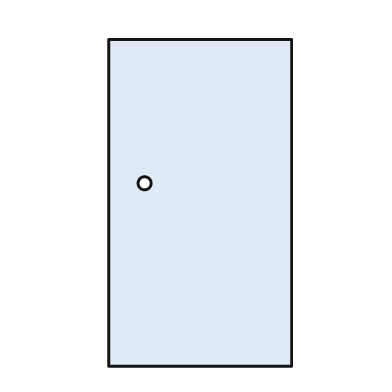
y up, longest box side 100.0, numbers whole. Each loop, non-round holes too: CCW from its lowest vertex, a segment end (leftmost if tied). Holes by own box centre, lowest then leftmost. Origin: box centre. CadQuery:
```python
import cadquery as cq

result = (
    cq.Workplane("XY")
    .moveTo(-28.0, -50.0)
    .lineTo(28.0, -50.0)
    .lineTo(28.0, 50.0)
    .lineTo(-28.0, 50.0)
    .close()
    .moveTo(-17.0, 6.0)
    .circle(2.0)
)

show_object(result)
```